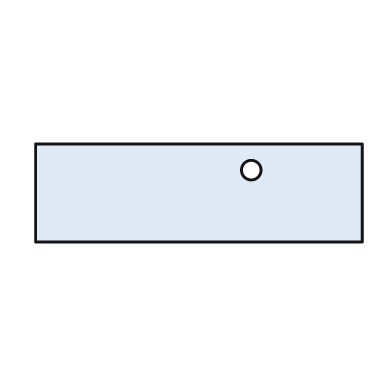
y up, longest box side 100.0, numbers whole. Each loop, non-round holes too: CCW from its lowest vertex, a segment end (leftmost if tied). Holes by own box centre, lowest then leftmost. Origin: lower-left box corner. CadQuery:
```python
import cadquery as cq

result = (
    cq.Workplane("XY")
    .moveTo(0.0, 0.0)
    .lineTo(100.0, 0.0)
    .lineTo(100.0, 30.0)
    .lineTo(0.0, 30.0)
    .close()
    .moveTo(66.0, 22.0)
    .circle(3.0)
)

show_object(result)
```